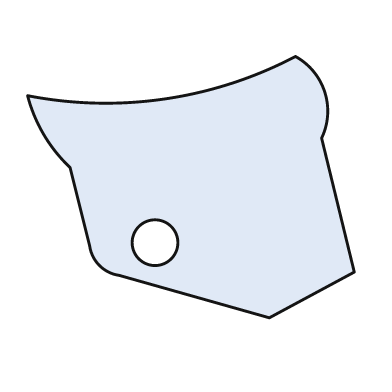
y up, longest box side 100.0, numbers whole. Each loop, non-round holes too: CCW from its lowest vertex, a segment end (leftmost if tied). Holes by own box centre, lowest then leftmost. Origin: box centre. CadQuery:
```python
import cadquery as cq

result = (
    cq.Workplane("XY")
    .moveTo(24.0, -40.0)
    .lineTo(50.0, -26.0)
    .lineTo(40.0, 15.0)
    .threePointArc((41.0, 29.0), (32.0, 40.0))
    .threePointArc((-8.0, 27.0), (-50.0, 28.0))
    .threePointArc((-45.0, 16.0), (-37.0, 6.0))
    .lineTo(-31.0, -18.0)
    .threePointArc((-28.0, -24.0), (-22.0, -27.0))
    .close()
    .moveTo(-11.0, -17.0)
    .circle(7.0)
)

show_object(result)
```